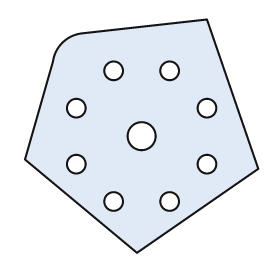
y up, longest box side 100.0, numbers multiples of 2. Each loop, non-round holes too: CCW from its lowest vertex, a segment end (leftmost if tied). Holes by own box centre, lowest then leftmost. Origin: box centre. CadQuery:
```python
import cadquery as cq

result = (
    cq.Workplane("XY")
    .moveTo(-2.0, -50.0)
    .lineTo(50.0, -14.0)
    .lineTo(28.0, 50.0)
    .lineTo(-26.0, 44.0)
    .threePointArc((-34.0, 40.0), (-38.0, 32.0))
    .lineTo(-50.0, -10.0)
    .close()
    .moveTo(-12.0, -28.0)
    .circle(4.0)
    .moveTo(12.0, -28.0)
    .circle(4.0)
    .moveTo(-28.0, -12.0)
    .circle(4.0)
    .moveTo(28.0, -12.0)
    .circle(4.0)
    .moveTo(0.0, 0.0)
    .circle(6.0)
    .moveTo(-28.0, 12.0)
    .circle(4.0)
    .moveTo(28.0, 12.0)
    .circle(4.0)
    .moveTo(-12.0, 28.0)
    .circle(4.0)
    .moveTo(12.0, 28.0)
    .circle(4.0)
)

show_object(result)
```